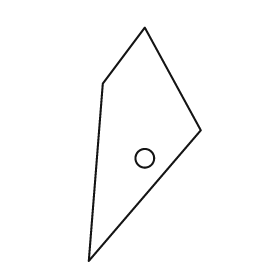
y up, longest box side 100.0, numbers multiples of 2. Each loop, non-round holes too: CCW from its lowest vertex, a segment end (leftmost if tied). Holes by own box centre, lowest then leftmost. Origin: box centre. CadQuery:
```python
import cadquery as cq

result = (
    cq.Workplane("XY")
    .moveTo(-24.0, -50.0)
    .lineTo(24.0, 6.0)
    .lineTo(0.0, 50.0)
    .lineTo(-18.0, 26.0)
    .close()
    .moveTo(0.0, -6.0)
    .circle(4.0)
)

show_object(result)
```